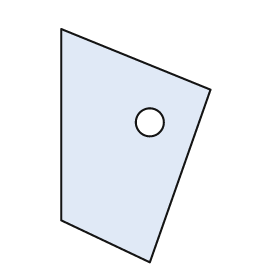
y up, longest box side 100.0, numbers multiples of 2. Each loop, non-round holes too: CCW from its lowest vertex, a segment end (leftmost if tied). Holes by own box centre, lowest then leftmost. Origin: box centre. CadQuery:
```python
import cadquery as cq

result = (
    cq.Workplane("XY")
    .moveTo(6.0, -50.0)
    .lineTo(32.0, 24.0)
    .lineTo(-32.0, 50.0)
    .lineTo(-32.0, -32.0)
    .close()
    .moveTo(6.0, 10.0)
    .circle(6.0)
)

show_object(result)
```